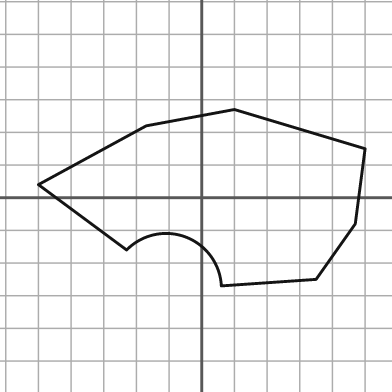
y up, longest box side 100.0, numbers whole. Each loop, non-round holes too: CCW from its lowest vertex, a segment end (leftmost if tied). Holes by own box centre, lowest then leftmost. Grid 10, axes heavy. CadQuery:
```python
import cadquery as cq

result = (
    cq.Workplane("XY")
    .moveTo(6.0, -27.0)
    .lineTo(35.0, -25.0)
    .lineTo(47.0, -8.0)
    .lineTo(50.0, 15.0)
    .lineTo(10.0, 27.0)
    .lineTo(-17.0, 22.0)
    .lineTo(-50.0, 4.0)
    .lineTo(-23.0, -16.0)
    .threePointArc((-5.0, -12.0), (6.0, -27.0))
    .close()
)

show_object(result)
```